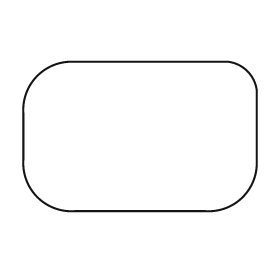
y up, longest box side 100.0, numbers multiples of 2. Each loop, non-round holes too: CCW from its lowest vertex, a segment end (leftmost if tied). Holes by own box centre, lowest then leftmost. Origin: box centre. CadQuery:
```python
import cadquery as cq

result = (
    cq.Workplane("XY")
    .moveTo(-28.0, -32.0)
    .lineTo(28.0, -32.0)
    .threePointArc((44.0, -26.0), (50.0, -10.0))
    .lineTo(50.0, 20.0)
    .threePointArc((46.0, 28.0), (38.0, 32.0))
    .lineTo(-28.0, 32.0)
    .threePointArc((-44.0, 26.0), (-50.0, 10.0))
    .lineTo(-50.0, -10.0)
    .threePointArc((-44.0, -26.0), (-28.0, -32.0))
    .close()
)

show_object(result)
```